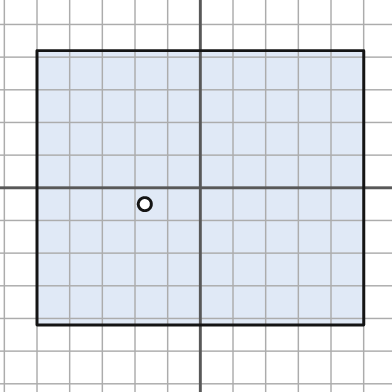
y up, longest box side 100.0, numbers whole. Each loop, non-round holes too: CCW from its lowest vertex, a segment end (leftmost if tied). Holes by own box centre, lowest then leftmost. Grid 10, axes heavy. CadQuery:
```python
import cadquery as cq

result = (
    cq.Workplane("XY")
    .moveTo(-50.0, -42.0)
    .lineTo(50.0, -42.0)
    .lineTo(50.0, 42.0)
    .lineTo(-50.0, 42.0)
    .close()
    .moveTo(-17.0, -5.0)
    .circle(2.0)
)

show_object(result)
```